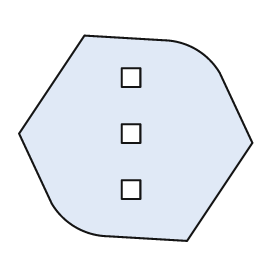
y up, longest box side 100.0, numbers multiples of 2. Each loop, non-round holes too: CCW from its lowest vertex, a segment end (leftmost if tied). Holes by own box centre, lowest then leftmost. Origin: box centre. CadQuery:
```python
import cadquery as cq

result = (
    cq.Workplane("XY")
    .moveTo(22.0, -44.0)
    .lineTo(50.0, -2.0)
    .lineTo(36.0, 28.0)
    .threePointArc((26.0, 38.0), (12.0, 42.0))
    .lineTo(-22.0, 44.0)
    .lineTo(-50.0, 2.0)
    .lineTo(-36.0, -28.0)
    .threePointArc((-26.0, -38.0), (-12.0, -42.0))
    .close()
    .moveTo(-6.0, -26.0)
    .lineTo(2.0, -26.0)
    .lineTo(2.0, -18.0)
    .lineTo(-6.0, -18.0)
    .close()
    .moveTo(-6.0, -2.0)
    .lineTo(2.0, -2.0)
    .lineTo(2.0, 6.0)
    .lineTo(-6.0, 6.0)
    .close()
    .moveTo(-6.0, 22.0)
    .lineTo(2.0, 22.0)
    .lineTo(2.0, 30.0)
    .lineTo(-6.0, 30.0)
    .close()
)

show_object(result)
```